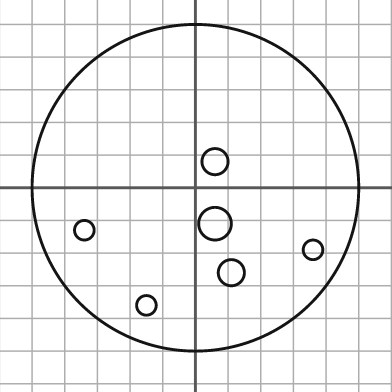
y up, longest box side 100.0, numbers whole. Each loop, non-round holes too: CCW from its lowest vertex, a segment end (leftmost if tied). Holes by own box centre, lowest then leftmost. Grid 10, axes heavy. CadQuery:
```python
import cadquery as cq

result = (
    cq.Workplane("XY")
    .moveTo(0.0, 0.0)
    .circle(50.0)
    .moveTo(-15.0, -36.0)
    .circle(3.0)
    .moveTo(11.0, -26.0)
    .circle(4.0)
    .moveTo(36.0, -19.0)
    .circle(3.0)
    .moveTo(-34.0, -13.0)
    .circle(3.0)
    .moveTo(6.0, -11.0)
    .circle(5.0)
    .moveTo(6.0, 8.0)
    .circle(4.0)
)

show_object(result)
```